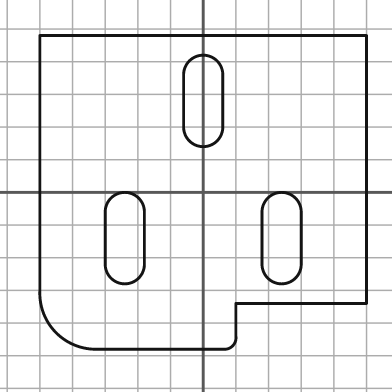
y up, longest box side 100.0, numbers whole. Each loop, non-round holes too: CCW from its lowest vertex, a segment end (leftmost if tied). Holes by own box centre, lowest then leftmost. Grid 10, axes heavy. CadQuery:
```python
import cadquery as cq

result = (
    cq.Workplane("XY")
    .moveTo(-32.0, -48.0)
    .lineTo(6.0, -48.0)
    .threePointArc((9.0, -47.0), (10.0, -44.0))
    .lineTo(10.0, -34.0)
    .lineTo(50.0, -34.0)
    .lineTo(50.0, 48.0)
    .lineTo(-50.0, 48.0)
    .lineTo(-50.0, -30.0)
    .threePointArc((-45.0, -43.0), (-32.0, -48.0))
    .close()
    .moveTo(-30.0, -22.0)
    .threePointArc((-24.0, -28.0), (-18.0, -22.0))
    .lineTo(-18.0, -6.0)
    .threePointArc((-24.0, 0.0), (-30.0, -6.0))
    .close()
    .moveTo(18.0, -22.0)
    .threePointArc((24.0, -28.0), (30.0, -22.0))
    .lineTo(30.0, -6.0)
    .threePointArc((24.0, 0.0), (18.0, -6.0))
    .close()
    .moveTo(-6.0, 20.0)
    .threePointArc((0.0, 14.0), (6.0, 20.0))
    .lineTo(6.0, 36.0)
    .threePointArc((0.0, 42.0), (-6.0, 36.0))
    .close()
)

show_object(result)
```